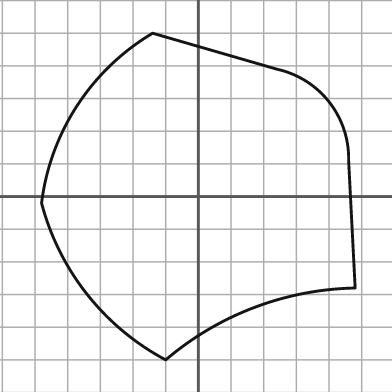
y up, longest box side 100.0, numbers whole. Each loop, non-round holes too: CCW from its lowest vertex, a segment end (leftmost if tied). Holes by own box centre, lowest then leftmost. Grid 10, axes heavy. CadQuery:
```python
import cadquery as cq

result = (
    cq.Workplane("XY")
    .moveTo(-10.0, -50.0)
    .threePointArc((17.0, -34.0), (48.0, -28.0))
    .lineTo(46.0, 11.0)
    .threePointArc((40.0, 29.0), (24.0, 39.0))
    .lineTo(-14.0, 50.0)
    .threePointArc((-37.0, 28.0), (-48.0, -2.0))
    .threePointArc((-34.0, -30.0), (-10.0, -50.0))
    .close()
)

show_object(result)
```